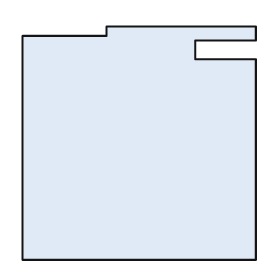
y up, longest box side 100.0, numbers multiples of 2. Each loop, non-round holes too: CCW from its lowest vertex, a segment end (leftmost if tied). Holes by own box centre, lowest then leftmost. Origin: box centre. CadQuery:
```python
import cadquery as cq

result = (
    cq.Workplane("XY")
    .moveTo(-50.0, -50.0)
    .lineTo(50.0, -50.0)
    .lineTo(50.0, 36.0)
    .lineTo(24.0, 36.0)
    .lineTo(24.0, 44.0)
    .lineTo(50.0, 44.0)
    .lineTo(50.0, 50.0)
    .lineTo(-14.0, 50.0)
    .lineTo(-14.0, 46.0)
    .lineTo(-50.0, 46.0)
    .close()
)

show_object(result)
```